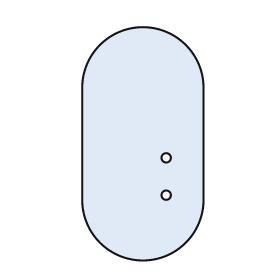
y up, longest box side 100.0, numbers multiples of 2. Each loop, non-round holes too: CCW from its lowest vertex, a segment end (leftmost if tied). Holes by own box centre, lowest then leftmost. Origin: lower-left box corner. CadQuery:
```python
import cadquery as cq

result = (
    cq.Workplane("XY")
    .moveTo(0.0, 26.0)
    .threePointArc((26.0, 0.0), (52.0, 26.0))
    .lineTo(52.0, 74.0)
    .threePointArc((26.0, 100.0), (0.0, 74.0))
    .close()
    .moveTo(36.0, 28.0)
    .circle(2.0)
    .moveTo(36.0, 44.0)
    .circle(2.0)
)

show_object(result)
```